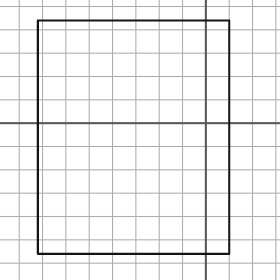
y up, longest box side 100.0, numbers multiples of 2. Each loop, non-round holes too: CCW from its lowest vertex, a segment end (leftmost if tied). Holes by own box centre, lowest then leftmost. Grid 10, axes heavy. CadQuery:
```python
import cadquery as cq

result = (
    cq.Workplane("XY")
    .moveTo(-72.0, -56.0)
    .lineTo(10.0, -56.0)
    .lineTo(10.0, 44.0)
    .lineTo(-72.0, 44.0)
    .close()
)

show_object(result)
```